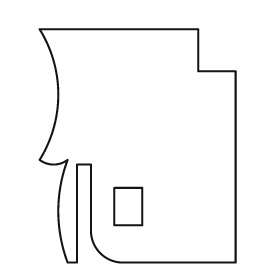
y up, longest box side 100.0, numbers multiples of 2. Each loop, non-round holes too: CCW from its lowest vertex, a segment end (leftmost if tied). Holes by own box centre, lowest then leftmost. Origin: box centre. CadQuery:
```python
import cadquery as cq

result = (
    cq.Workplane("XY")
    .moveTo(-30.0, -50.0)
    .lineTo(-26.0, -50.0)
    .lineTo(-26.0, -8.0)
    .lineTo(-20.0, -8.0)
    .lineTo(-20.0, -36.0)
    .threePointArc((-16.0, -46.0), (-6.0, -50.0))
    .lineTo(42.0, -50.0)
    .lineTo(42.0, 32.0)
    .lineTo(26.0, 32.0)
    .lineTo(26.0, 50.0)
    .lineTo(-42.0, 50.0)
    .threePointArc((-34.0, 22.0), (-42.0, -6.0))
    .threePointArc((-36.0, -8.0), (-30.0, -6.0))
    .threePointArc((-34.0, -28.0), (-30.0, -50.0))
    .close()
    .moveTo(-10.0, -34.0)
    .lineTo(2.0, -34.0)
    .lineTo(2.0, -18.0)
    .lineTo(-10.0, -18.0)
    .close()
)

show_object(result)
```